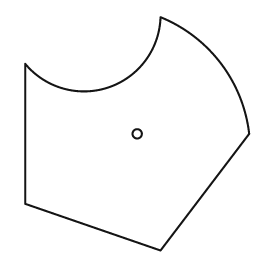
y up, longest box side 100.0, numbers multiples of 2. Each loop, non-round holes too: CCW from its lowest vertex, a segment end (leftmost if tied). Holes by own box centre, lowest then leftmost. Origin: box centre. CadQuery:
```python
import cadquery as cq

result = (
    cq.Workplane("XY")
    .moveTo(10.0, -50.0)
    .lineTo(48.0, 0.0)
    .threePointArc((36.0, 30.0), (10.0, 50.0))
    .threePointArc((-12.0, 20.0), (-48.0, 30.0))
    .lineTo(-48.0, -30.0)
    .close()
    .moveTo(0.0, 0.0)
    .circle(2.0)
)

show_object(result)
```